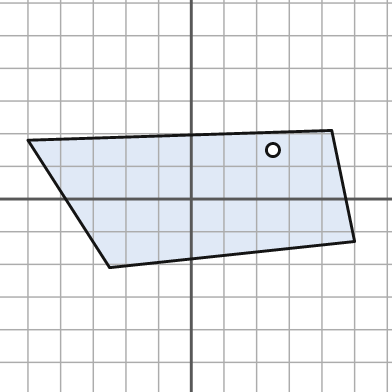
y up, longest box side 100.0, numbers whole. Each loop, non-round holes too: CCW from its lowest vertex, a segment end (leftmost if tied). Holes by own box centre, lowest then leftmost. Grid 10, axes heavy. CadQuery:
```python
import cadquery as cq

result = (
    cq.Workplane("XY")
    .moveTo(-25.0, -21.0)
    .lineTo(50.0, -13.0)
    .lineTo(43.0, 21.0)
    .lineTo(-50.0, 18.0)
    .close()
    .moveTo(25.0, 15.0)
    .circle(2.0)
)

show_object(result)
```